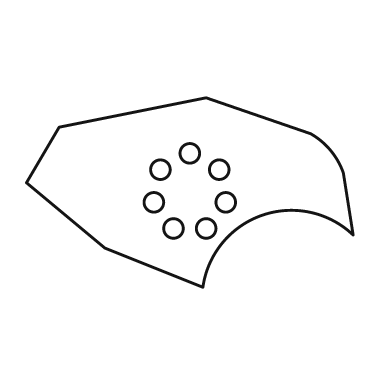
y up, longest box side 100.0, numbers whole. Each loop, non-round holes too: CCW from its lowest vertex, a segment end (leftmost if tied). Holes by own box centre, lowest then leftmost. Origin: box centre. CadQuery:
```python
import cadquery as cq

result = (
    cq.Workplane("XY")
    .moveTo(4.0, -29.0)
    .threePointArc((22.0, -7.0), (50.0, -13.0))
    .lineTo(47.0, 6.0)
    .threePointArc((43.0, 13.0), (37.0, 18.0))
    .lineTo(5.0, 29.0)
    .lineTo(-40.0, 20.0)
    .lineTo(-50.0, 3.0)
    .lineTo(-26.0, -17.0)
    .close()
    .moveTo(-5.0, -11.0)
    .circle(3.0)
    .moveTo(5.0, -11.0)
    .circle(3.0)
    .moveTo(-11.0, -3.0)
    .circle(3.0)
    .moveTo(11.0, -3.0)
    .circle(3.0)
    .moveTo(-9.0, 7.0)
    .circle(3.0)
    .moveTo(9.0, 7.0)
    .circle(3.0)
    .moveTo(0.0, 12.0)
    .circle(3.0)
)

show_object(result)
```